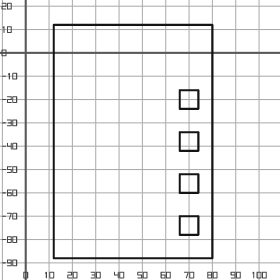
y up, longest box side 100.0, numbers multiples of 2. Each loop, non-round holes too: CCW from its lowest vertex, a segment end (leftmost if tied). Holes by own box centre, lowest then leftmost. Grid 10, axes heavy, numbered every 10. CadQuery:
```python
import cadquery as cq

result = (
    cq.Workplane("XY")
    .moveTo(12.0, -88.0)
    .lineTo(80.0, -88.0)
    .lineTo(80.0, 12.0)
    .lineTo(12.0, 12.0)
    .close()
    .moveTo(66.0, -78.0)
    .lineTo(74.0, -78.0)
    .lineTo(74.0, -70.0)
    .lineTo(66.0, -70.0)
    .close()
    .moveTo(66.0, -60.0)
    .lineTo(74.0, -60.0)
    .lineTo(74.0, -52.0)
    .lineTo(66.0, -52.0)
    .close()
    .moveTo(66.0, -42.0)
    .lineTo(74.0, -42.0)
    .lineTo(74.0, -34.0)
    .lineTo(66.0, -34.0)
    .close()
    .moveTo(66.0, -24.0)
    .lineTo(74.0, -24.0)
    .lineTo(74.0, -16.0)
    .lineTo(66.0, -16.0)
    .close()
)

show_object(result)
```